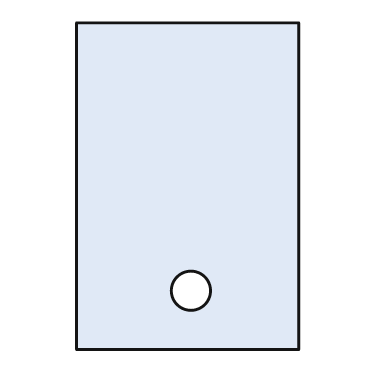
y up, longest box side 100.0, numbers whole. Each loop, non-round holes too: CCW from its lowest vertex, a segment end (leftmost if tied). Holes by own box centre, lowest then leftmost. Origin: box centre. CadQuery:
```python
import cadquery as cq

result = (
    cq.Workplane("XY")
    .moveTo(-34.0, -50.0)
    .lineTo(34.0, -50.0)
    .lineTo(34.0, 50.0)
    .lineTo(-34.0, 50.0)
    .close()
    .moveTo(1.0, -32.0)
    .circle(6.0)
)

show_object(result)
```